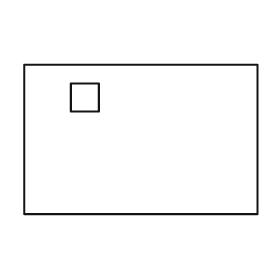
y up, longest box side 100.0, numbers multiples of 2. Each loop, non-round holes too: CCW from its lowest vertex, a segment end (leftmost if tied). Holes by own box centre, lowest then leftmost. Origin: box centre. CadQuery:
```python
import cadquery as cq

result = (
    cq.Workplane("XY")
    .moveTo(-50.0, -32.0)
    .lineTo(50.0, -32.0)
    .lineTo(50.0, 32.0)
    .lineTo(-50.0, 32.0)
    .close()
    .moveTo(-30.0, 12.0)
    .lineTo(-18.0, 12.0)
    .lineTo(-18.0, 24.0)
    .lineTo(-30.0, 24.0)
    .close()
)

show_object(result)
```